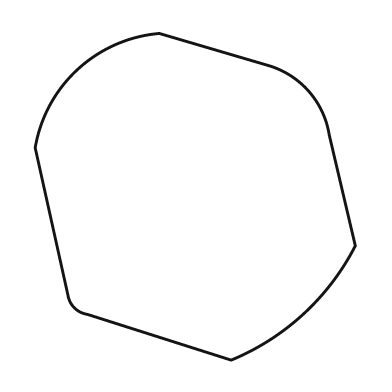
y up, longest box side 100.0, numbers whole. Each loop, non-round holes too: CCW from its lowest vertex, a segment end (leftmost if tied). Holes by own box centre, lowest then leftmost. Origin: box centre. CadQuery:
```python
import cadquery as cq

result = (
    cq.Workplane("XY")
    .moveTo(11.0, -50.0)
    .threePointArc((33.0, -36.0), (49.0, -15.0))
    .lineTo(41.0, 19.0)
    .threePointArc((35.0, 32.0), (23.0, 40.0))
    .lineTo(-11.0, 50.0)
    .threePointArc((-36.0, 39.0), (-49.0, 15.0))
    .lineTo(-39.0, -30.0)
    .threePointArc((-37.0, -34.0), (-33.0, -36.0))
    .close()
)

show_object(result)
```